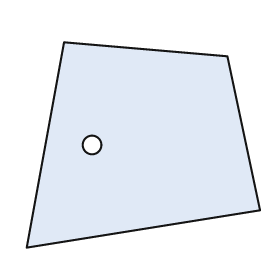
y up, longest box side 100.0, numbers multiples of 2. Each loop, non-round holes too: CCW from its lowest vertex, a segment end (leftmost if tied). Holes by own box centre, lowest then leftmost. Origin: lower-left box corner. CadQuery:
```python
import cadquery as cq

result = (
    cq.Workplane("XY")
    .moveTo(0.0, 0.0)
    .lineTo(100.0, 16.0)
    .lineTo(86.0, 82.0)
    .lineTo(16.0, 88.0)
    .close()
    .moveTo(28.0, 44.0)
    .circle(4.0)
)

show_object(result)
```